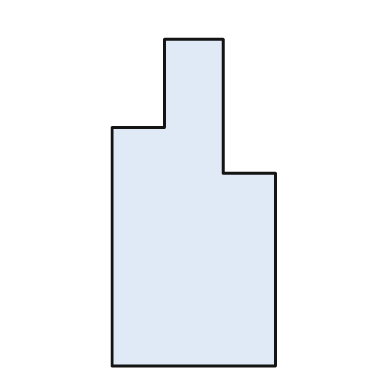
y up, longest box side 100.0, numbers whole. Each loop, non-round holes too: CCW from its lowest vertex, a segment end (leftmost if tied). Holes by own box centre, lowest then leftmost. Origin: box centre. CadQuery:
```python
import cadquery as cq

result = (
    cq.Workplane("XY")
    .moveTo(-25.0, -50.0)
    .lineTo(25.0, -50.0)
    .lineTo(25.0, 9.0)
    .lineTo(9.0, 9.0)
    .lineTo(9.0, 50.0)
    .lineTo(-9.0, 50.0)
    .lineTo(-9.0, 23.0)
    .lineTo(-25.0, 23.0)
    .close()
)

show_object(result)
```